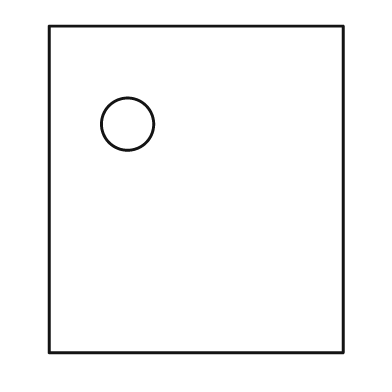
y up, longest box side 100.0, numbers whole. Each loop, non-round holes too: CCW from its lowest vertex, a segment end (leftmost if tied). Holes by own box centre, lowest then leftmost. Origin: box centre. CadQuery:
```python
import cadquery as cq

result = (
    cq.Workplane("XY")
    .moveTo(-45.0, -50.0)
    .lineTo(45.0, -50.0)
    .lineTo(45.0, 50.0)
    .lineTo(-45.0, 50.0)
    .close()
    .moveTo(-21.0, 20.0)
    .circle(8.0)
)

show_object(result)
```